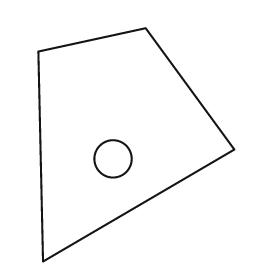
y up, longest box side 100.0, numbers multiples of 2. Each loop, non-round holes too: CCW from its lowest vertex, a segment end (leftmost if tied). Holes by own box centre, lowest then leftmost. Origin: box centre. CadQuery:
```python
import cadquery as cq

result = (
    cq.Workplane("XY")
    .moveTo(-40.0, -50.0)
    .lineTo(42.0, -2.0)
    .lineTo(4.0, 50.0)
    .lineTo(-42.0, 40.0)
    .close()
    .moveTo(-10.0, -6.0)
    .circle(8.0)
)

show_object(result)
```